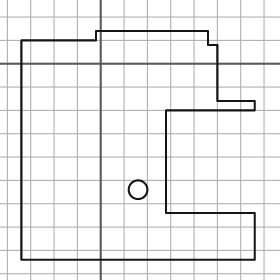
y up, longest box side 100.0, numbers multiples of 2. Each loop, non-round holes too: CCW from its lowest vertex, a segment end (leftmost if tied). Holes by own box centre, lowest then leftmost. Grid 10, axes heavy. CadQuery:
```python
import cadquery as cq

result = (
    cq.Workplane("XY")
    .moveTo(-34.0, -84.0)
    .lineTo(66.0, -84.0)
    .lineTo(66.0, -64.0)
    .lineTo(28.0, -64.0)
    .lineTo(28.0, -20.0)
    .lineTo(66.0, -20.0)
    .lineTo(66.0, -16.0)
    .lineTo(50.0, -16.0)
    .lineTo(50.0, 8.0)
    .lineTo(46.0, 8.0)
    .lineTo(46.0, 14.0)
    .lineTo(-2.0, 14.0)
    .lineTo(-2.0, 10.0)
    .lineTo(-34.0, 10.0)
    .close()
    .moveTo(16.0, -54.0)
    .circle(4.0)
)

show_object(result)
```